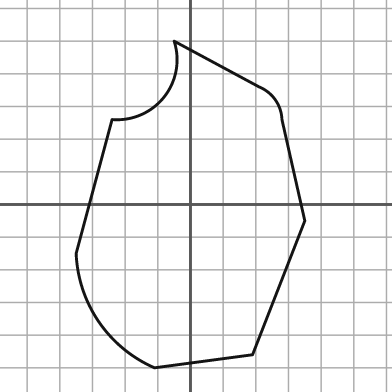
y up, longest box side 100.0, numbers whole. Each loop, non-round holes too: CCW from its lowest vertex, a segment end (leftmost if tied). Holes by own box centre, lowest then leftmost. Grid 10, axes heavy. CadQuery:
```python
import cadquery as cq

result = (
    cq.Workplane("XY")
    .moveTo(-11.0, -50.0)
    .lineTo(19.0, -46.0)
    .lineTo(35.0, -5.0)
    .lineTo(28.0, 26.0)
    .threePointArc((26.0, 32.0), (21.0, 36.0))
    .lineTo(-5.0, 50.0)
    .threePointArc((-8.0, 33.0), (-24.0, 26.0))
    .lineTo(-35.0, -15.0)
    .threePointArc((-28.0, -36.0), (-11.0, -50.0))
    .close()
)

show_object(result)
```